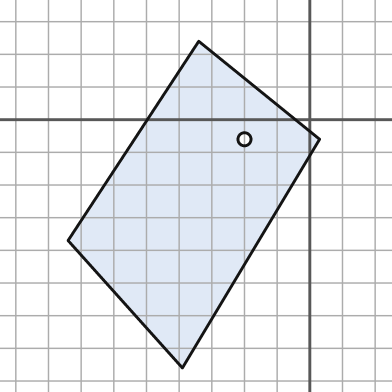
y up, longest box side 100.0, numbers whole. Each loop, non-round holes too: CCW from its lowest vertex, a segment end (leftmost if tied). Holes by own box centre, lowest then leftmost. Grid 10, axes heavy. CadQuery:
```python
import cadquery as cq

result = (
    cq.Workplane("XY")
    .moveTo(-39.0, -76.0)
    .lineTo(3.0, -6.0)
    .lineTo(-34.0, 24.0)
    .lineTo(-74.0, -37.0)
    .close()
    .moveTo(-20.0, -6.0)
    .circle(2.0)
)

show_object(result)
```